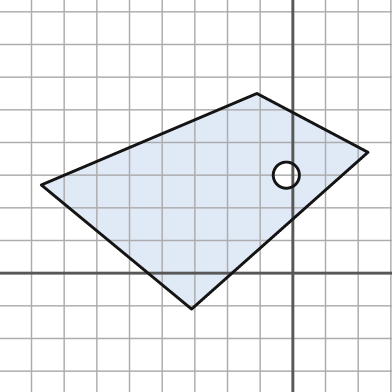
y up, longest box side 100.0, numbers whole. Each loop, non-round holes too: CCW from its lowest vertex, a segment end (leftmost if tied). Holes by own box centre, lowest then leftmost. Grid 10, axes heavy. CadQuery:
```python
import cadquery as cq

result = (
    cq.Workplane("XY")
    .moveTo(-31.0, -11.0)
    .lineTo(23.0, 37.0)
    .lineTo(-11.0, 55.0)
    .lineTo(-77.0, 27.0)
    .close()
    .moveTo(-2.0, 30.0)
    .circle(4.0)
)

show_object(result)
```